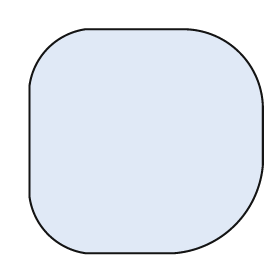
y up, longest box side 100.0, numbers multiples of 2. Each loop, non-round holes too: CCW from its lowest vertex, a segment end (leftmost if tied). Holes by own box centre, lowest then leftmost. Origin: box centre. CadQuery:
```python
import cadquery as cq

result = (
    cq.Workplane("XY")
    .moveTo(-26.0, -48.0)
    .lineTo(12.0, -48.0)
    .threePointArc((38.0, -36.0), (50.0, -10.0))
    .lineTo(50.0, 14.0)
    .threePointArc((40.0, 38.0), (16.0, 48.0))
    .lineTo(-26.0, 48.0)
    .threePointArc((-42.0, 40.0), (-50.0, 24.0))
    .lineTo(-50.0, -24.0)
    .threePointArc((-42.0, -40.0), (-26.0, -48.0))
    .close()
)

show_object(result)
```